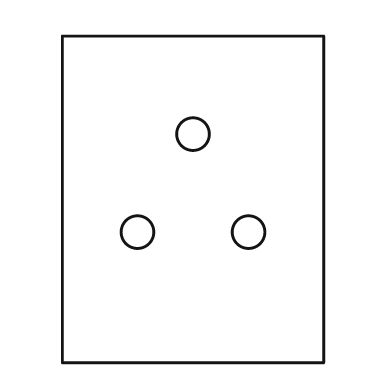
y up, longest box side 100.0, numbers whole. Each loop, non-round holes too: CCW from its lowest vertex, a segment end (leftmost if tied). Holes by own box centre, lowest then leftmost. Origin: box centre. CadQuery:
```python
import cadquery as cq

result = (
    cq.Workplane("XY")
    .moveTo(-40.0, -50.0)
    .lineTo(40.0, -50.0)
    .lineTo(40.0, 50.0)
    .lineTo(-40.0, 50.0)
    .close()
    .moveTo(-17.0, -10.0)
    .circle(5.0)
    .moveTo(17.0, -10.0)
    .circle(5.0)
    .moveTo(0.0, 20.0)
    .circle(5.0)
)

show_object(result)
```